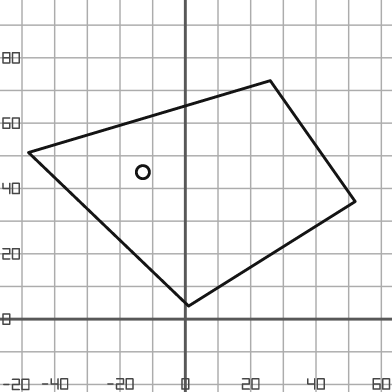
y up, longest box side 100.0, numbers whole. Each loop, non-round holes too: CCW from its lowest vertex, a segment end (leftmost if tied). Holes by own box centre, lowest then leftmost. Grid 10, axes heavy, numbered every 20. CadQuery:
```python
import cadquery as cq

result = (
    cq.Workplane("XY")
    .moveTo(1.0, 4.0)
    .lineTo(52.0, 36.0)
    .lineTo(26.0, 73.0)
    .lineTo(-48.0, 51.0)
    .close()
    .moveTo(-13.0, 45.0)
    .circle(2.0)
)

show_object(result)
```